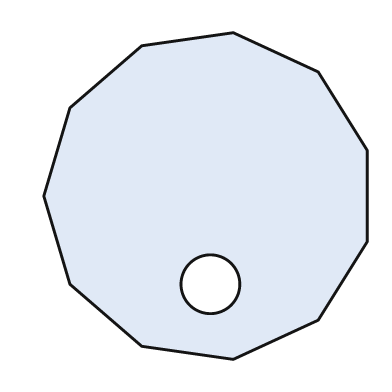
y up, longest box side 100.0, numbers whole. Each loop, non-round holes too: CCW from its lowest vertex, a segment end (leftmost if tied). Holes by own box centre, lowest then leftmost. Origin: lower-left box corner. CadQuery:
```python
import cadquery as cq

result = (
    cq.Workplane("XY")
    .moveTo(58.0, 0.0)
    .lineTo(84.0, 12.0)
    .lineTo(99.0, 36.0)
    .lineTo(99.0, 64.0)
    .lineTo(84.0, 88.0)
    .lineTo(58.0, 100.0)
    .lineTo(30.0, 96.0)
    .lineTo(8.0, 77.0)
    .lineTo(0.0, 50.0)
    .lineTo(8.0, 23.0)
    .lineTo(30.0, 4.0)
    .close()
    .moveTo(51.0, 23.0)
    .circle(9.0)
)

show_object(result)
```